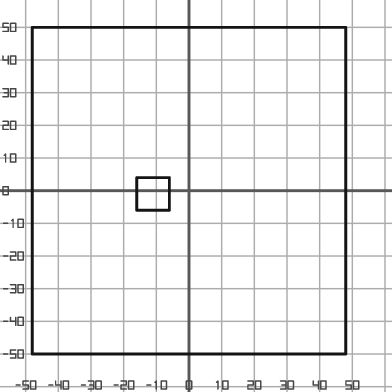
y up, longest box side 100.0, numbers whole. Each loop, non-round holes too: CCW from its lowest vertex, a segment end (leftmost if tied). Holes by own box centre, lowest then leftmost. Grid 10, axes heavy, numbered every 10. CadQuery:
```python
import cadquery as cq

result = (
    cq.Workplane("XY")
    .moveTo(-48.0, -50.0)
    .lineTo(48.0, -50.0)
    .lineTo(48.0, 50.0)
    .lineTo(-48.0, 50.0)
    .close()
    .moveTo(-16.0, -6.0)
    .lineTo(-6.0, -6.0)
    .lineTo(-6.0, 4.0)
    .lineTo(-16.0, 4.0)
    .close()
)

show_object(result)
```